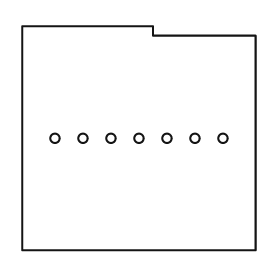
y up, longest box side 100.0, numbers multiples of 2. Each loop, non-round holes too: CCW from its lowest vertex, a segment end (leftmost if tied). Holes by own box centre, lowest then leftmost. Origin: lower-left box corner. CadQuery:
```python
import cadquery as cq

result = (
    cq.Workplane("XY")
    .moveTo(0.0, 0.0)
    .lineTo(100.0, 0.0)
    .lineTo(100.0, 92.0)
    .lineTo(56.0, 92.0)
    .lineTo(56.0, 96.0)
    .lineTo(0.0, 96.0)
    .close()
    .moveTo(14.0, 48.0)
    .circle(2.0)
    .moveTo(26.0, 48.0)
    .circle(2.0)
    .moveTo(38.0, 48.0)
    .circle(2.0)
    .moveTo(50.0, 48.0)
    .circle(2.0)
    .moveTo(62.0, 48.0)
    .circle(2.0)
    .moveTo(74.0, 48.0)
    .circle(2.0)
    .moveTo(86.0, 48.0)
    .circle(2.0)
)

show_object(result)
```